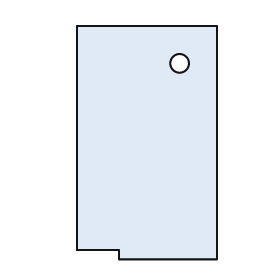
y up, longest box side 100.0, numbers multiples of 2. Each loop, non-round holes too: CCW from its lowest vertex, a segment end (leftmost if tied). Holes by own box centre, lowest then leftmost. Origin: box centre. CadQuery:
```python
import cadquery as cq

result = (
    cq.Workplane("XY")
    .moveTo(-12.0, -50.0)
    .lineTo(30.0, -50.0)
    .lineTo(30.0, 50.0)
    .lineTo(-30.0, 50.0)
    .lineTo(-30.0, -46.0)
    .lineTo(-12.0, -46.0)
    .close()
    .moveTo(14.0, 34.0)
    .circle(4.0)
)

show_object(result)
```